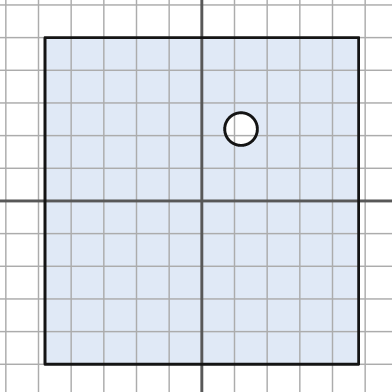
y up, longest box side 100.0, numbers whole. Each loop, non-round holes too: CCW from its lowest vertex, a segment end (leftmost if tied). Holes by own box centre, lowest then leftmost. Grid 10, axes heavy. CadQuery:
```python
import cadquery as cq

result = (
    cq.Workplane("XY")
    .moveTo(-48.0, -50.0)
    .lineTo(48.0, -50.0)
    .lineTo(48.0, 50.0)
    .lineTo(-48.0, 50.0)
    .close()
    .moveTo(12.0, 22.0)
    .circle(5.0)
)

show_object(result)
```